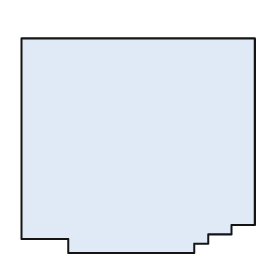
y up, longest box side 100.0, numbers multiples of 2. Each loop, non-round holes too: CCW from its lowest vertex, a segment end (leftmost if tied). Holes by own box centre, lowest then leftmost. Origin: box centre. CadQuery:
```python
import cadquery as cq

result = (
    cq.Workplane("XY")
    .moveTo(-30.0, -46.0)
    .lineTo(24.0, -46.0)
    .lineTo(24.0, -42.0)
    .lineTo(30.0, -42.0)
    .lineTo(30.0, -38.0)
    .lineTo(40.0, -38.0)
    .lineTo(40.0, -34.0)
    .lineTo(50.0, -34.0)
    .lineTo(50.0, 46.0)
    .lineTo(-50.0, 46.0)
    .lineTo(-50.0, -40.0)
    .lineTo(-30.0, -40.0)
    .close()
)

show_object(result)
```